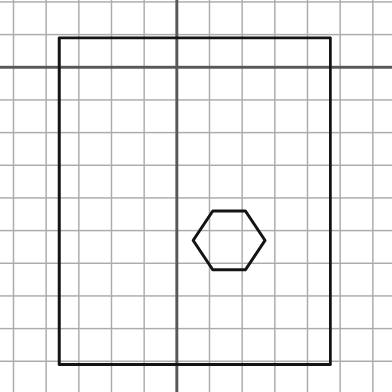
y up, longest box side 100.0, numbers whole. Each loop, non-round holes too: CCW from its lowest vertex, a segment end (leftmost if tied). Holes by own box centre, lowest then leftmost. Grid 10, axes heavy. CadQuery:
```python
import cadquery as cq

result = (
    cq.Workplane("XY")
    .moveTo(-36.0, -91.0)
    .lineTo(47.0, -91.0)
    .lineTo(47.0, 9.0)
    .lineTo(-36.0, 9.0)
    .close()
    .moveTo(11.0, -62.0)
    .lineTo(21.0, -62.0)
    .lineTo(27.0, -53.0)
    .lineTo(21.0, -44.0)
    .lineTo(11.0, -44.0)
    .lineTo(5.0, -53.0)
    .close()
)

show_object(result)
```